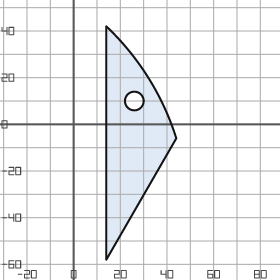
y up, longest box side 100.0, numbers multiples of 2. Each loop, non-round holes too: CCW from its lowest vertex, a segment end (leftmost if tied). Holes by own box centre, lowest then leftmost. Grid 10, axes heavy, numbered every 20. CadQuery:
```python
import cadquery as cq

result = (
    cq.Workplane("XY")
    .moveTo(14.0, -58.0)
    .lineTo(44.0, -6.0)
    .threePointArc((32.0, 20.0), (14.0, 42.0))
    .close()
    .moveTo(26.0, 10.0)
    .circle(4.0)
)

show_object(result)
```